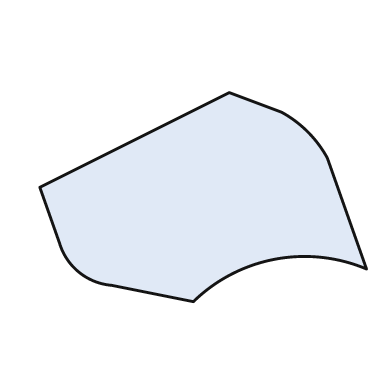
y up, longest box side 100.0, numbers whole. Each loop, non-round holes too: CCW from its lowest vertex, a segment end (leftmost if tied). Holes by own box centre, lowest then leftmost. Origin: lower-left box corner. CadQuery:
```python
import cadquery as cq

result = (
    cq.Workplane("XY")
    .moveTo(47.0, 0.0)
    .threePointArc((72.0, 13.0), (100.0, 10.0))
    .lineTo(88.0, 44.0)
    .threePointArc((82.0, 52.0), (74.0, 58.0))
    .lineTo(58.0, 64.0)
    .lineTo(0.0, 35.0)
    .lineTo(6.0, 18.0)
    .threePointArc((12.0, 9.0), (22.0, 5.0))
    .close()
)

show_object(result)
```